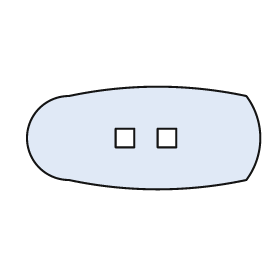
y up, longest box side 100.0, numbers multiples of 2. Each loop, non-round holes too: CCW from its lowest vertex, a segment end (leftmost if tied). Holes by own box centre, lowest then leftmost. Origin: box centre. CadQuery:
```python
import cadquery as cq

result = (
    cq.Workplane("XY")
    .moveTo(-32.0, -18.0)
    .threePointArc((6.0, -22.0), (44.0, -18.0))
    .threePointArc((50.0, 0.0), (44.0, 18.0))
    .threePointArc((6.0, 22.0), (-32.0, 18.0))
    .threePointArc((-50.0, 0.0), (-32.0, -18.0))
    .close()
    .moveTo(-12.0, -4.0)
    .lineTo(-4.0, -4.0)
    .lineTo(-4.0, 4.0)
    .lineTo(-12.0, 4.0)
    .close()
    .moveTo(6.0, -4.0)
    .lineTo(14.0, -4.0)
    .lineTo(14.0, 4.0)
    .lineTo(6.0, 4.0)
    .close()
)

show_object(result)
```